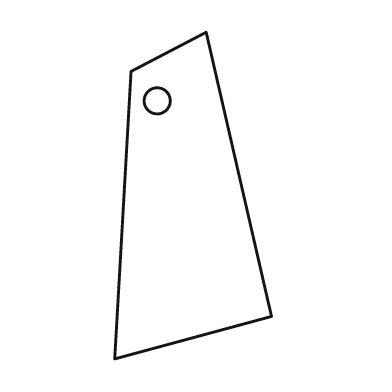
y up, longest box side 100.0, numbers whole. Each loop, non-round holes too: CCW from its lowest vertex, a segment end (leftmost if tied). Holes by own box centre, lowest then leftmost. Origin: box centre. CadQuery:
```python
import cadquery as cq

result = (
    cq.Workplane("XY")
    .moveTo(-24.0, -50.0)
    .lineTo(24.0, -37.0)
    .lineTo(4.0, 50.0)
    .lineTo(-19.0, 38.0)
    .close()
    .moveTo(-11.0, 29.0)
    .circle(4.0)
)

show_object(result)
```